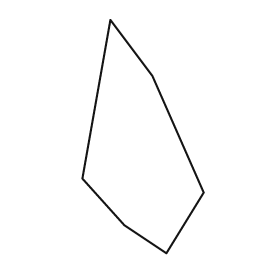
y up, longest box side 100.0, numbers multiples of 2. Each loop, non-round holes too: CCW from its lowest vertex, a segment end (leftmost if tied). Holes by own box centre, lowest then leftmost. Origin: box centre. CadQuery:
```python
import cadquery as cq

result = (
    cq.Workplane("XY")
    .moveTo(10.0, -50.0)
    .lineTo(26.0, -24.0)
    .lineTo(4.0, 26.0)
    .lineTo(-14.0, 50.0)
    .lineTo(-26.0, -18.0)
    .lineTo(-8.0, -38.0)
    .close()
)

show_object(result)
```